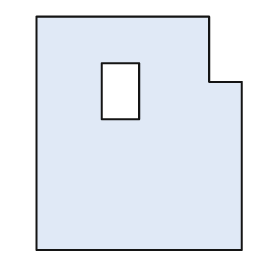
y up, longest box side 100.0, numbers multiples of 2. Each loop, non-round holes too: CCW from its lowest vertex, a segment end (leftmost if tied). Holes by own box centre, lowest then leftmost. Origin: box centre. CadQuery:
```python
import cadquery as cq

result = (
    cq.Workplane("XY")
    .moveTo(-44.0, -50.0)
    .lineTo(44.0, -50.0)
    .lineTo(44.0, 22.0)
    .lineTo(30.0, 22.0)
    .lineTo(30.0, 50.0)
    .lineTo(-44.0, 50.0)
    .close()
    .moveTo(-16.0, 6.0)
    .lineTo(0.0, 6.0)
    .lineTo(0.0, 30.0)
    .lineTo(-16.0, 30.0)
    .close()
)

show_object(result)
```